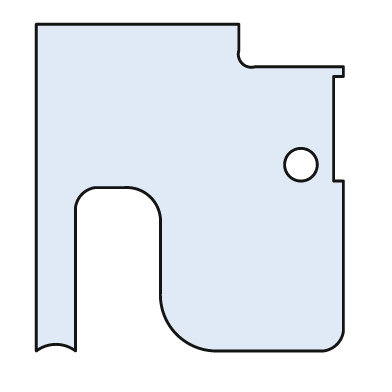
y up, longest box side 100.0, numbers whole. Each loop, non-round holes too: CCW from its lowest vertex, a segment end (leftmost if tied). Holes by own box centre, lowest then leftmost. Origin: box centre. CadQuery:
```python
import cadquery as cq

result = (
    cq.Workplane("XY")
    .moveTo(-47.0, -50.0)
    .threePointArc((-41.0, -48.0), (-35.0, -50.0))
    .lineTo(-35.0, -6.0)
    .threePointArc((-33.0, -2.0), (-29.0, 0.0))
    .lineTo(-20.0, 0.0)
    .threePointArc((-12.0, -3.0), (-9.0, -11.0))
    .lineTo(-9.0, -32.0)
    .threePointArc((-4.0, -45.0), (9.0, -50.0))
    .lineTo(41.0, -50.0)
    .threePointArc((45.0, -48.0), (47.0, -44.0))
    .lineTo(47.0, 2.0)
    .lineTo(44.0, 2.0)
    .lineTo(44.0, 34.0)
    .lineTo(47.0, 34.0)
    .lineTo(47.0, 37.0)
    .lineTo(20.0, 37.0)
    .threePointArc((16.0, 38.0), (15.0, 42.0))
    .lineTo(15.0, 50.0)
    .lineTo(-47.0, 50.0)
    .close()
    .moveTo(34.0, 7.0)
    .circle(5.0)
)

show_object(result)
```